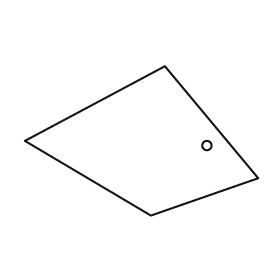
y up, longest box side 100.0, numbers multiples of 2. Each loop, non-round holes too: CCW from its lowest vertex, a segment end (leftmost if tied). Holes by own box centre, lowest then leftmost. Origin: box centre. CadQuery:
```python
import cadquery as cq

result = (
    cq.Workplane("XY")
    .moveTo(4.0, -32.0)
    .lineTo(50.0, -16.0)
    .lineTo(10.0, 32.0)
    .lineTo(-50.0, 0.0)
    .close()
    .moveTo(28.0, -2.0)
    .circle(2.0)
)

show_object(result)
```